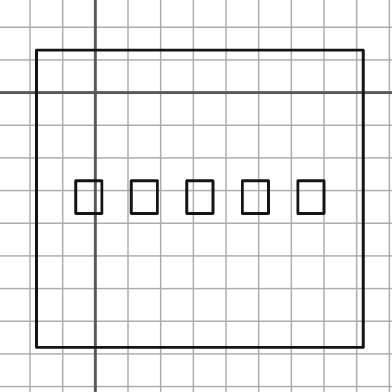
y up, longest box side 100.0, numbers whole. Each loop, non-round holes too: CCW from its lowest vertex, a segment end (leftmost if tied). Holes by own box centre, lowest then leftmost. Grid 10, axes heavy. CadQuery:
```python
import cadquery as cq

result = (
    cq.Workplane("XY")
    .moveTo(-18.0, -78.0)
    .lineTo(82.0, -78.0)
    .lineTo(82.0, 13.0)
    .lineTo(-18.0, 13.0)
    .close()
    .moveTo(-6.0, -37.0)
    .lineTo(2.0, -37.0)
    .lineTo(2.0, -27.0)
    .lineTo(-6.0, -27.0)
    .close()
    .moveTo(11.0, -37.0)
    .lineTo(19.0, -37.0)
    .lineTo(19.0, -27.0)
    .lineTo(11.0, -27.0)
    .close()
    .moveTo(28.0, -37.0)
    .lineTo(36.0, -37.0)
    .lineTo(36.0, -27.0)
    .lineTo(28.0, -27.0)
    .close()
    .moveTo(45.0, -37.0)
    .lineTo(53.0, -37.0)
    .lineTo(53.0, -27.0)
    .lineTo(45.0, -27.0)
    .close()
    .moveTo(62.0, -37.0)
    .lineTo(70.0, -37.0)
    .lineTo(70.0, -27.0)
    .lineTo(62.0, -27.0)
    .close()
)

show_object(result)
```